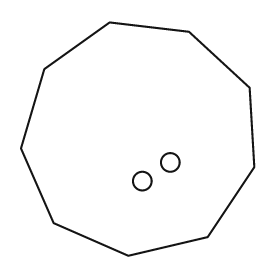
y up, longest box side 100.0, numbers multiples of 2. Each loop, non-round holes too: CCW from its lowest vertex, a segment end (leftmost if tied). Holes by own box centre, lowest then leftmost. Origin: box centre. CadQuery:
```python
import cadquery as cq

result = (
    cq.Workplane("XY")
    .moveTo(-4.0, -50.0)
    .lineTo(30.0, -42.0)
    .lineTo(50.0, -12.0)
    .lineTo(48.0, 22.0)
    .lineTo(22.0, 46.0)
    .lineTo(-12.0, 50.0)
    .lineTo(-40.0, 30.0)
    .lineTo(-50.0, -4.0)
    .lineTo(-36.0, -36.0)
    .close()
    .moveTo(2.0, -18.0)
    .circle(4.0)
    .moveTo(14.0, -10.0)
    .circle(4.0)
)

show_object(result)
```